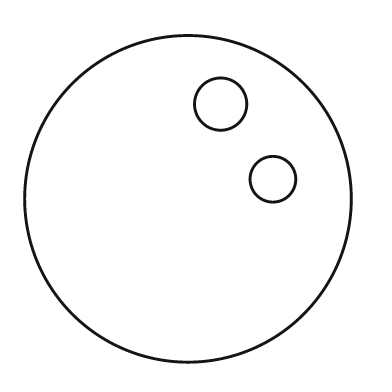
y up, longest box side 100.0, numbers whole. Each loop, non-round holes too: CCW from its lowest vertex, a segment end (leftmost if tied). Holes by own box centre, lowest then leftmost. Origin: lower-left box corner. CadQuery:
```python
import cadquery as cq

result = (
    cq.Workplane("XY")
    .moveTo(50.0, 50.0)
    .circle(50.0)
    .moveTo(76.0, 56.0)
    .circle(7.0)
    .moveTo(60.0, 79.0)
    .circle(8.0)
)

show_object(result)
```